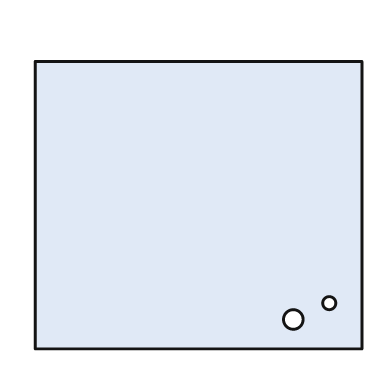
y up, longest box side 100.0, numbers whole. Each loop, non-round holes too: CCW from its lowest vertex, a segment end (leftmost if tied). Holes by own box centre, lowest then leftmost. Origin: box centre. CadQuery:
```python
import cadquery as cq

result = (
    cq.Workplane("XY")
    .moveTo(-50.0, -44.0)
    .lineTo(50.0, -44.0)
    .lineTo(50.0, 44.0)
    .lineTo(-50.0, 44.0)
    .close()
    .moveTo(29.0, -35.0)
    .circle(3.0)
    .moveTo(40.0, -30.0)
    .circle(2.0)
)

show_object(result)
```